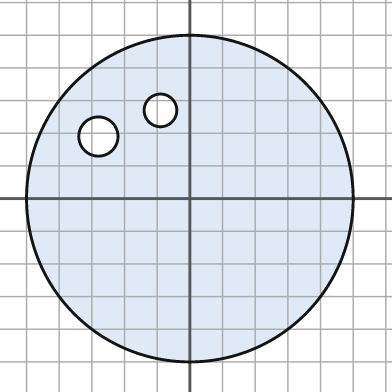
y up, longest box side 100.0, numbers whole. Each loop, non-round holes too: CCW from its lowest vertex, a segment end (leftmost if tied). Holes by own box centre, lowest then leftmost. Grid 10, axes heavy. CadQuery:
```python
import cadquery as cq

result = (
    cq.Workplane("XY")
    .moveTo(0.0, 0.0)
    .circle(50.0)
    .moveTo(-28.0, 19.0)
    .circle(6.0)
    .moveTo(-9.0, 27.0)
    .circle(5.0)
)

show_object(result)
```